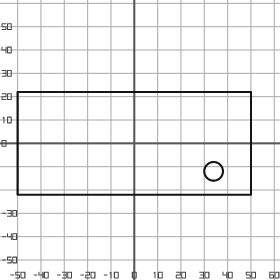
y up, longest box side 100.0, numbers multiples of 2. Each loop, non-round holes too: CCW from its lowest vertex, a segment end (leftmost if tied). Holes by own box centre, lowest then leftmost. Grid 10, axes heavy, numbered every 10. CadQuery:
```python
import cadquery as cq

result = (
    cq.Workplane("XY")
    .moveTo(-50.0, -22.0)
    .lineTo(50.0, -22.0)
    .lineTo(50.0, 22.0)
    .lineTo(-50.0, 22.0)
    .close()
    .moveTo(34.0, -12.0)
    .circle(4.0)
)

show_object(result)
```